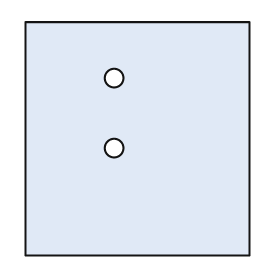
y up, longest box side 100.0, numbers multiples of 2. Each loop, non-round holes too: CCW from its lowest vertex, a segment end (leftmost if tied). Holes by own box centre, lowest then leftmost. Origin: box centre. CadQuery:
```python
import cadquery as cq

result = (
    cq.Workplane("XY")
    .moveTo(-48.0, -50.0)
    .lineTo(48.0, -50.0)
    .lineTo(48.0, 50.0)
    .lineTo(-48.0, 50.0)
    .close()
    .moveTo(-10.0, -4.0)
    .circle(4.0)
    .moveTo(-10.0, 26.0)
    .circle(4.0)
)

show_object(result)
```